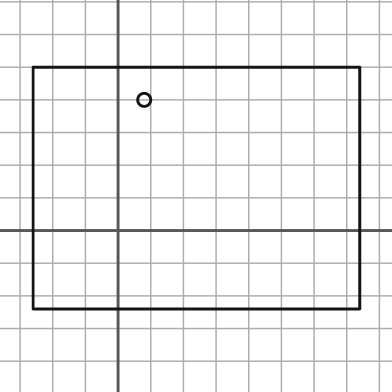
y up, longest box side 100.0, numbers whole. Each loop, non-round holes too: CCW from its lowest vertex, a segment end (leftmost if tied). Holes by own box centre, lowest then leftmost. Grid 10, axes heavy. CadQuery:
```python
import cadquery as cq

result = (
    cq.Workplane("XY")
    .moveTo(-26.0, -24.0)
    .lineTo(74.0, -24.0)
    .lineTo(74.0, 50.0)
    .lineTo(-26.0, 50.0)
    .close()
    .moveTo(8.0, 40.0)
    .circle(2.0)
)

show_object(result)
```